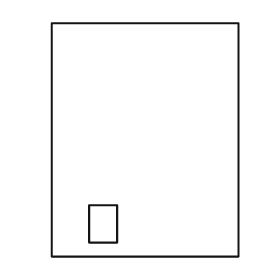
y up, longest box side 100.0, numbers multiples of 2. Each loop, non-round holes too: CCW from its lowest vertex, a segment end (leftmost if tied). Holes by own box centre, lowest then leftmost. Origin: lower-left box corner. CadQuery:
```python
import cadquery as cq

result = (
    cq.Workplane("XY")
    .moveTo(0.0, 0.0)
    .lineTo(80.0, 0.0)
    .lineTo(80.0, 100.0)
    .lineTo(0.0, 100.0)
    .close()
    .moveTo(16.0, 6.0)
    .lineTo(28.0, 6.0)
    .lineTo(28.0, 22.0)
    .lineTo(16.0, 22.0)
    .close()
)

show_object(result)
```